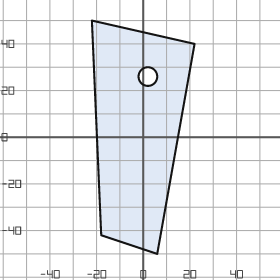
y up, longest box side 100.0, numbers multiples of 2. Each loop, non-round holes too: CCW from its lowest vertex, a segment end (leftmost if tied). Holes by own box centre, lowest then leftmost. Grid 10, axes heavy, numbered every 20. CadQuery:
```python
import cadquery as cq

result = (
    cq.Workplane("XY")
    .moveTo(6.0, -50.0)
    .lineTo(22.0, 40.0)
    .lineTo(-22.0, 50.0)
    .lineTo(-18.0, -42.0)
    .close()
    .moveTo(2.0, 26.0)
    .circle(4.0)
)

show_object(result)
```